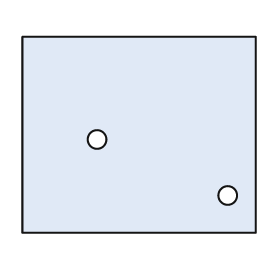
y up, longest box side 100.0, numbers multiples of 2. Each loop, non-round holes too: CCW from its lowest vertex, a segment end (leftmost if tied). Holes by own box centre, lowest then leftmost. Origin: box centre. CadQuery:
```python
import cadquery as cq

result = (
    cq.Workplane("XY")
    .moveTo(-50.0, -42.0)
    .lineTo(50.0, -42.0)
    .lineTo(50.0, 42.0)
    .lineTo(-50.0, 42.0)
    .close()
    .moveTo(38.0, -26.0)
    .circle(4.0)
    .moveTo(-18.0, -2.0)
    .circle(4.0)
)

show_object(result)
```